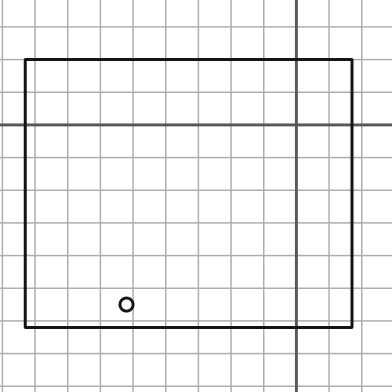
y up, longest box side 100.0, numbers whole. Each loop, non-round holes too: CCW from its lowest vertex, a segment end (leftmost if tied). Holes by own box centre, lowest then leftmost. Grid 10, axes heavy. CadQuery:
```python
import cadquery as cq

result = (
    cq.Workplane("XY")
    .moveTo(-83.0, -62.0)
    .lineTo(17.0, -62.0)
    .lineTo(17.0, 20.0)
    .lineTo(-83.0, 20.0)
    .close()
    .moveTo(-52.0, -55.0)
    .circle(2.0)
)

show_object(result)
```